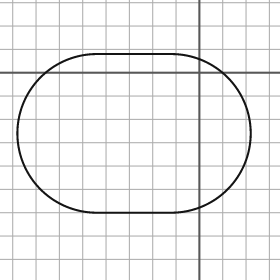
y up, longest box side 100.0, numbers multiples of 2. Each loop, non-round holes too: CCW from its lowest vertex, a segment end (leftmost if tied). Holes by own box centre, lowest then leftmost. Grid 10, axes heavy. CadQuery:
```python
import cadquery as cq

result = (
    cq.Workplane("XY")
    .moveTo(-44.0, -60.0)
    .lineTo(-12.0, -60.0)
    .threePointArc((22.0, -26.0), (-12.0, 8.0))
    .lineTo(-44.0, 8.0)
    .threePointArc((-78.0, -26.0), (-44.0, -60.0))
    .close()
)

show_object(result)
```